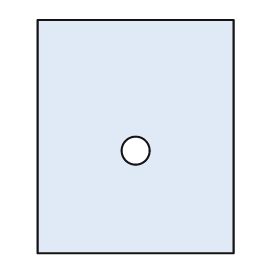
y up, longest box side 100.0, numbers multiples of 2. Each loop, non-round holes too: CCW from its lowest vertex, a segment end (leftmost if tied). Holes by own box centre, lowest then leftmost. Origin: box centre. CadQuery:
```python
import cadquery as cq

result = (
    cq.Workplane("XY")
    .moveTo(-42.0, -50.0)
    .lineTo(42.0, -50.0)
    .lineTo(42.0, 50.0)
    .lineTo(-42.0, 50.0)
    .close()
    .moveTo(0.0, -6.0)
    .circle(6.0)
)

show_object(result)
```